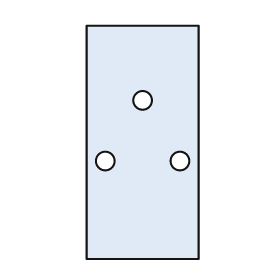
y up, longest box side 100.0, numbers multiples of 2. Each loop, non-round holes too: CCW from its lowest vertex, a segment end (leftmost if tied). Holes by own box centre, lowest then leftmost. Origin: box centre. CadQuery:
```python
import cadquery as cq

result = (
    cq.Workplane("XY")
    .moveTo(-24.0, -50.0)
    .lineTo(24.0, -50.0)
    .lineTo(24.0, 50.0)
    .lineTo(-24.0, 50.0)
    .close()
    .moveTo(-16.0, -8.0)
    .circle(4.0)
    .moveTo(16.0, -8.0)
    .circle(4.0)
    .moveTo(0.0, 18.0)
    .circle(4.0)
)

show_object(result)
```